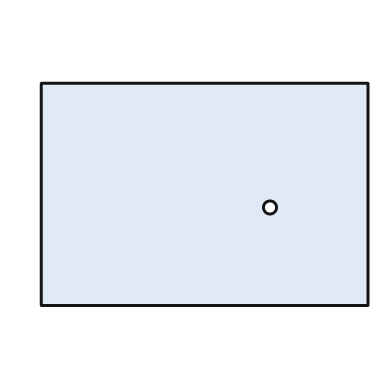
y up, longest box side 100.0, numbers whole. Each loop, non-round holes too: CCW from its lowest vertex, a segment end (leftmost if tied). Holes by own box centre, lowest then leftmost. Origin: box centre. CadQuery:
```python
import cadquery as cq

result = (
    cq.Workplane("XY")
    .moveTo(-50.0, -34.0)
    .lineTo(50.0, -34.0)
    .lineTo(50.0, 34.0)
    .lineTo(-50.0, 34.0)
    .close()
    .moveTo(20.0, -4.0)
    .circle(2.0)
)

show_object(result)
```